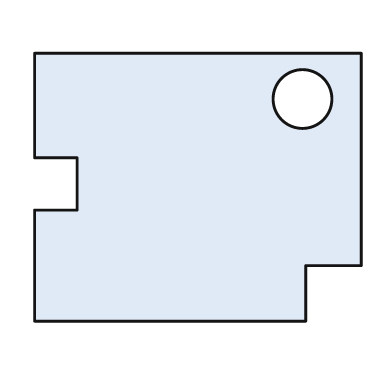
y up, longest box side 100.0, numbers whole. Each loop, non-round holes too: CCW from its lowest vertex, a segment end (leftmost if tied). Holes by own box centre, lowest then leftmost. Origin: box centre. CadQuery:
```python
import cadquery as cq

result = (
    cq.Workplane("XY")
    .moveTo(-50.0, -41.0)
    .lineTo(33.0, -41.0)
    .lineTo(33.0, -24.0)
    .lineTo(50.0, -24.0)
    .lineTo(50.0, 41.0)
    .lineTo(-50.0, 41.0)
    .lineTo(-50.0, 9.0)
    .lineTo(-37.0, 9.0)
    .lineTo(-37.0, -7.0)
    .lineTo(-50.0, -7.0)
    .close()
    .moveTo(32.0, 27.0)
    .circle(9.0)
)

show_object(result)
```